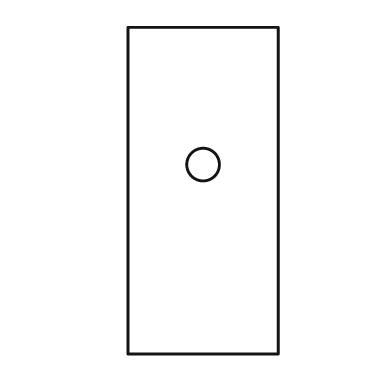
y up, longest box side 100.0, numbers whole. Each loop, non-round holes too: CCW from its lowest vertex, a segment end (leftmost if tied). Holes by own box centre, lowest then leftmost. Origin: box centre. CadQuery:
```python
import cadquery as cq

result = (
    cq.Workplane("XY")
    .moveTo(-23.0, -50.0)
    .lineTo(23.0, -50.0)
    .lineTo(23.0, 50.0)
    .lineTo(-23.0, 50.0)
    .close()
    .moveTo(0.0, 8.0)
    .circle(5.0)
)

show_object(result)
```